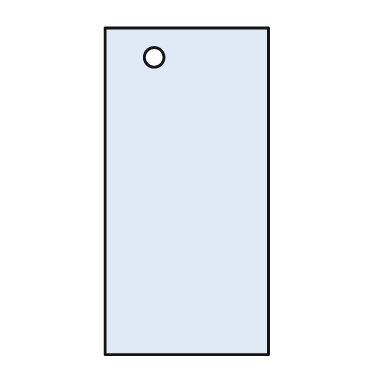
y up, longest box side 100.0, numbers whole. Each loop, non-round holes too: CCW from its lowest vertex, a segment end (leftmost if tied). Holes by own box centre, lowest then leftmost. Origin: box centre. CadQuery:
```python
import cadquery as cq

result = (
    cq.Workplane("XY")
    .moveTo(-25.0, -50.0)
    .lineTo(25.0, -50.0)
    .lineTo(25.0, 50.0)
    .lineTo(-25.0, 50.0)
    .close()
    .moveTo(-10.0, 41.0)
    .circle(3.0)
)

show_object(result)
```